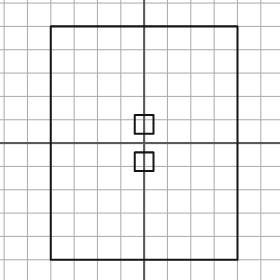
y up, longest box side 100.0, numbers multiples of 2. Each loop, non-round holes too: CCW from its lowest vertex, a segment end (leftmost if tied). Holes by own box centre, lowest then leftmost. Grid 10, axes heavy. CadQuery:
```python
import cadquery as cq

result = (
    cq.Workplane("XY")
    .moveTo(-40.0, -50.0)
    .lineTo(40.0, -50.0)
    .lineTo(40.0, 50.0)
    .lineTo(-40.0, 50.0)
    .close()
    .moveTo(-4.0, -12.0)
    .lineTo(4.0, -12.0)
    .lineTo(4.0, -4.0)
    .lineTo(-4.0, -4.0)
    .close()
    .moveTo(-4.0, 4.0)
    .lineTo(4.0, 4.0)
    .lineTo(4.0, 12.0)
    .lineTo(-4.0, 12.0)
    .close()
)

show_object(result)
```